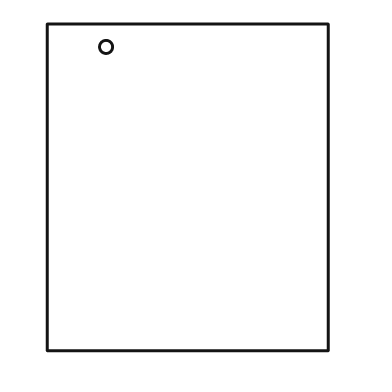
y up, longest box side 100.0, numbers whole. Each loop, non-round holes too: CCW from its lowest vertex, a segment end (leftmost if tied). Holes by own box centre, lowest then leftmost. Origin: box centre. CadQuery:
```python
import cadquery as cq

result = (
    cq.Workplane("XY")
    .moveTo(-43.0, -50.0)
    .lineTo(43.0, -50.0)
    .lineTo(43.0, 50.0)
    .lineTo(-43.0, 50.0)
    .close()
    .moveTo(-25.0, 43.0)
    .circle(2.0)
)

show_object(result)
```